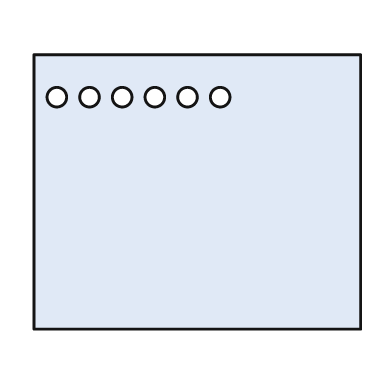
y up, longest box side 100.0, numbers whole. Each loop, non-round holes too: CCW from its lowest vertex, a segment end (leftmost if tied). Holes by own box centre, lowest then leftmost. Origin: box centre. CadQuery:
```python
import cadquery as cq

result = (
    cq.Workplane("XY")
    .moveTo(-50.0, -42.0)
    .lineTo(50.0, -42.0)
    .lineTo(50.0, 42.0)
    .lineTo(-50.0, 42.0)
    .close()
    .moveTo(-43.0, 29.0)
    .circle(3.0)
    .moveTo(-33.0, 29.0)
    .circle(3.0)
    .moveTo(-23.0, 29.0)
    .circle(3.0)
    .moveTo(-13.0, 29.0)
    .circle(3.0)
    .moveTo(-3.0, 29.0)
    .circle(3.0)
    .moveTo(7.0, 29.0)
    .circle(3.0)
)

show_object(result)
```